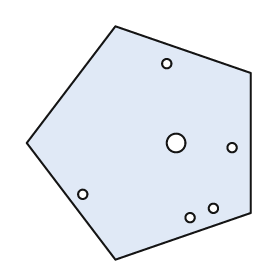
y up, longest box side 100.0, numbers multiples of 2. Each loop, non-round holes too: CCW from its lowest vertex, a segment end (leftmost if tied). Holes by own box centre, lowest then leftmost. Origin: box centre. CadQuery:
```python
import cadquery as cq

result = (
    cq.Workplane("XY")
    .moveTo(-10.0, -50.0)
    .lineTo(48.0, -30.0)
    .lineTo(48.0, 30.0)
    .lineTo(-10.0, 50.0)
    .lineTo(-48.0, 0.0)
    .close()
    .moveTo(22.0, -32.0)
    .circle(2.0)
    .moveTo(32.0, -28.0)
    .circle(2.0)
    .moveTo(-24.0, -22.0)
    .circle(2.0)
    .moveTo(40.0, -2.0)
    .circle(2.0)
    .moveTo(16.0, 0.0)
    .circle(4.0)
    .moveTo(12.0, 34.0)
    .circle(2.0)
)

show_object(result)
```